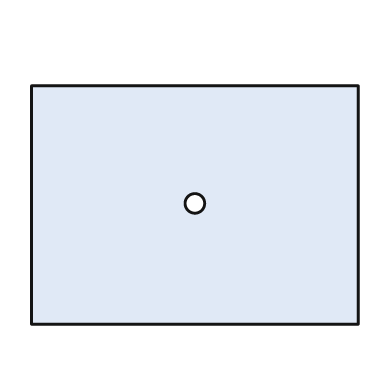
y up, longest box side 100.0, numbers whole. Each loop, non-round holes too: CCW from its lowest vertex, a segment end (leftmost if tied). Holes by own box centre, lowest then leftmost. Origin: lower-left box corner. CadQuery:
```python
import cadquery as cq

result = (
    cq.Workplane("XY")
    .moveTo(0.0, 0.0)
    .lineTo(100.0, 0.0)
    .lineTo(100.0, 73.0)
    .lineTo(0.0, 73.0)
    .close()
    .moveTo(50.0, 37.0)
    .circle(3.0)
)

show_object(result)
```